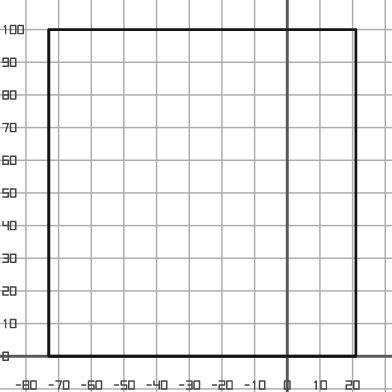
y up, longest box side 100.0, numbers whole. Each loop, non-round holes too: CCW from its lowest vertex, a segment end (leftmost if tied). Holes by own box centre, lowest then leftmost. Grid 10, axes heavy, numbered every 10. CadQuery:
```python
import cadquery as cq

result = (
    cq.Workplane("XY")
    .moveTo(-73.0, 0.0)
    .lineTo(21.0, 0.0)
    .lineTo(21.0, 100.0)
    .lineTo(-73.0, 100.0)
    .close()
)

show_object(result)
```